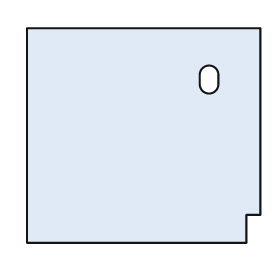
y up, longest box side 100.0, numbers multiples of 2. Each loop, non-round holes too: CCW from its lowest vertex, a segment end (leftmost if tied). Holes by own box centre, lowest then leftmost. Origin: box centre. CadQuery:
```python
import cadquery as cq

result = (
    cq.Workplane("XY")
    .moveTo(-50.0, -46.0)
    .lineTo(44.0, -46.0)
    .lineTo(44.0, -34.0)
    .lineTo(50.0, -34.0)
    .lineTo(50.0, 46.0)
    .lineTo(-50.0, 46.0)
    .close()
    .moveTo(24.0, 22.0)
    .threePointArc((28.0, 18.0), (32.0, 22.0))
    .lineTo(32.0, 26.0)
    .threePointArc((28.0, 30.0), (24.0, 26.0))
    .close()
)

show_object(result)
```